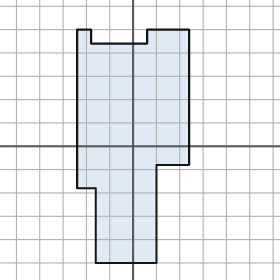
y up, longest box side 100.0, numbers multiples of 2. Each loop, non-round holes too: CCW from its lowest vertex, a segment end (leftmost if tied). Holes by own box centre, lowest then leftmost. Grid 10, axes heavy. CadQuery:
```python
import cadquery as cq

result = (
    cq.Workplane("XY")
    .moveTo(-16.0, -50.0)
    .lineTo(10.0, -50.0)
    .lineTo(10.0, -8.0)
    .lineTo(24.0, -8.0)
    .lineTo(24.0, 50.0)
    .lineTo(6.0, 50.0)
    .lineTo(6.0, 44.0)
    .lineTo(-18.0, 44.0)
    .lineTo(-18.0, 50.0)
    .lineTo(-24.0, 50.0)
    .lineTo(-24.0, -18.0)
    .lineTo(-16.0, -18.0)
    .close()
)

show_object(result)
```